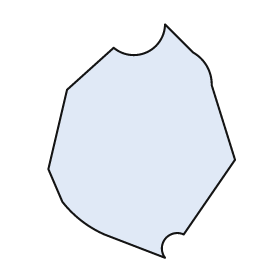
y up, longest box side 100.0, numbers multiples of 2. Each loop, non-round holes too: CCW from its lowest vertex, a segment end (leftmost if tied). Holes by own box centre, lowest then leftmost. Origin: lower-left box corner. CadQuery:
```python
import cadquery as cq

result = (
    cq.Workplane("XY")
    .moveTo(50.0, 0.0)
    .threePointArc((50.0, 8.0), (58.0, 10.0))
    .lineTo(80.0, 42.0)
    .lineTo(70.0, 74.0)
    .threePointArc((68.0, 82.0), (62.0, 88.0))
    .lineTo(50.0, 100.0)
    .threePointArc((42.0, 88.0), (28.0, 90.0))
    .lineTo(8.0, 72.0)
    .lineTo(0.0, 38.0)
    .lineTo(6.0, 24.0)
    .threePointArc((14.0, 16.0), (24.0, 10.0))
    .close()
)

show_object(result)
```